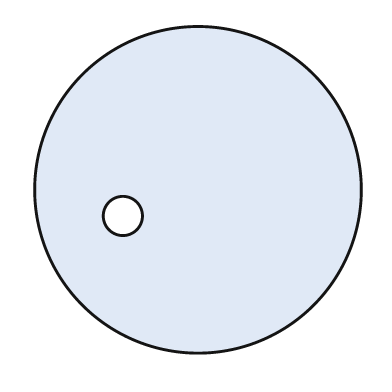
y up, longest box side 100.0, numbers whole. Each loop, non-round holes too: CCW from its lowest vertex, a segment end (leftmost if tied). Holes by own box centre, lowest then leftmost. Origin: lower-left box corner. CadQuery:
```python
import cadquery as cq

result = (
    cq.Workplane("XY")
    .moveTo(50.0, 50.0)
    .circle(50.0)
    .moveTo(27.0, 42.0)
    .circle(6.0)
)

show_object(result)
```